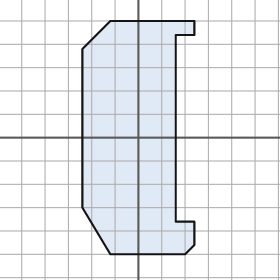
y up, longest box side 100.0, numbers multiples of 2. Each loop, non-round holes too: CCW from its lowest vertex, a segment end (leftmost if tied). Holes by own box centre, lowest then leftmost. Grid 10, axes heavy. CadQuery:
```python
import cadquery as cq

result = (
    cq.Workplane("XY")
    .moveTo(-12.0, -50.0)
    .lineTo(20.0, -50.0)
    .lineTo(24.0, -46.0)
    .lineTo(24.0, -36.0)
    .lineTo(16.0, -36.0)
    .lineTo(16.0, 44.0)
    .lineTo(24.0, 44.0)
    .lineTo(24.0, 50.0)
    .lineTo(-12.0, 50.0)
    .lineTo(-24.0, 38.0)
    .lineTo(-24.0, -30.0)
    .close()
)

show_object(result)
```